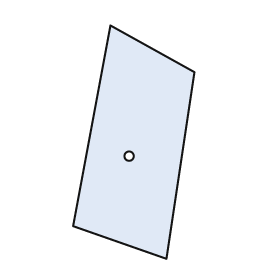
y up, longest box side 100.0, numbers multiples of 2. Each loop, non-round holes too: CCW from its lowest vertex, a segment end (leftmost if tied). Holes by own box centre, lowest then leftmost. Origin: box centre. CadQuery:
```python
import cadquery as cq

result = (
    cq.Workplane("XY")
    .moveTo(14.0, -50.0)
    .lineTo(26.0, 30.0)
    .lineTo(-10.0, 50.0)
    .lineTo(-26.0, -36.0)
    .close()
    .moveTo(-2.0, -6.0)
    .circle(2.0)
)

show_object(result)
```